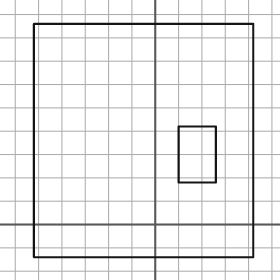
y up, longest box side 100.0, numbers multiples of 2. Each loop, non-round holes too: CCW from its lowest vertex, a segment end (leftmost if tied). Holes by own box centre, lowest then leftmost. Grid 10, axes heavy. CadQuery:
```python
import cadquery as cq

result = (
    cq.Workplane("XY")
    .moveTo(-52.0, -14.0)
    .lineTo(42.0, -14.0)
    .lineTo(42.0, 86.0)
    .lineTo(-52.0, 86.0)
    .close()
    .moveTo(10.0, 18.0)
    .lineTo(26.0, 18.0)
    .lineTo(26.0, 42.0)
    .lineTo(10.0, 42.0)
    .close()
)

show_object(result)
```